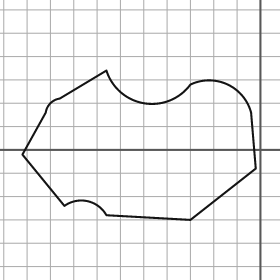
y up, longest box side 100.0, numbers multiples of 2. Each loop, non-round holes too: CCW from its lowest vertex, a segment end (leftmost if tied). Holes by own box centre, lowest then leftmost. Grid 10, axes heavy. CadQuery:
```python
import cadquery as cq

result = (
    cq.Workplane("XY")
    .moveTo(-30.0, -30.0)
    .lineTo(-2.0, -8.0)
    .lineTo(-4.0, 16.0)
    .threePointArc((-14.0, 28.0), (-30.0, 28.0))
    .threePointArc((-50.0, 20.0), (-66.0, 34.0))
    .lineTo(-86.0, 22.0)
    .threePointArc((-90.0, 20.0), (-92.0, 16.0))
    .lineTo(-102.0, -2.0)
    .lineTo(-84.0, -24.0)
    .threePointArc((-74.0, -22.0), (-66.0, -28.0))
    .close()
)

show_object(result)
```